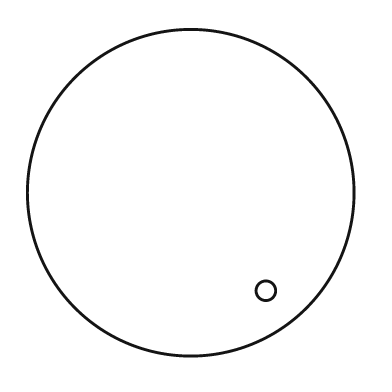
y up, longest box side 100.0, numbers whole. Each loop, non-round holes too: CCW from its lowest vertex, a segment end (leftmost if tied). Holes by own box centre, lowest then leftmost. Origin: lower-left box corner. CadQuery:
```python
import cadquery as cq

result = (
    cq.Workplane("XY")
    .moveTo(50.0, 50.0)
    .circle(50.0)
    .moveTo(73.0, 20.0)
    .circle(3.0)
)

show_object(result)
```